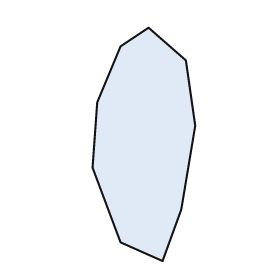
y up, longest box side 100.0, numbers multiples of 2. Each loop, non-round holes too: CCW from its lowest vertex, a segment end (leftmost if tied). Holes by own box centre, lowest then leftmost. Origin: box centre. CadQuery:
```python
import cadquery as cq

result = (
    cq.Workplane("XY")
    .moveTo(8.0, -50.0)
    .lineTo(16.0, -28.0)
    .lineTo(22.0, 8.0)
    .lineTo(18.0, 36.0)
    .lineTo(2.0, 50.0)
    .lineTo(-10.0, 42.0)
    .lineTo(-20.0, 18.0)
    .lineTo(-22.0, -10.0)
    .lineTo(-10.0, -42.0)
    .close()
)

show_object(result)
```